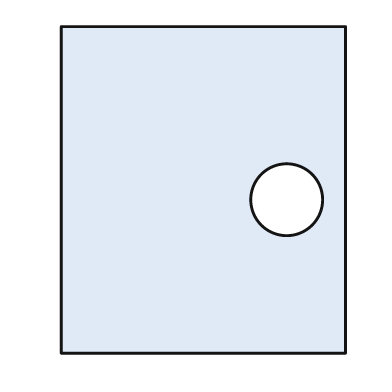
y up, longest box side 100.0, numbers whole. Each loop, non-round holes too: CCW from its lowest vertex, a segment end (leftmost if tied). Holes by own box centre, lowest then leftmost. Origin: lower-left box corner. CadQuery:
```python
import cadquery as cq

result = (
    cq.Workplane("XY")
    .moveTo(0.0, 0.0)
    .lineTo(87.0, 0.0)
    .lineTo(87.0, 100.0)
    .lineTo(0.0, 100.0)
    .close()
    .moveTo(69.0, 47.0)
    .circle(11.0)
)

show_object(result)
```